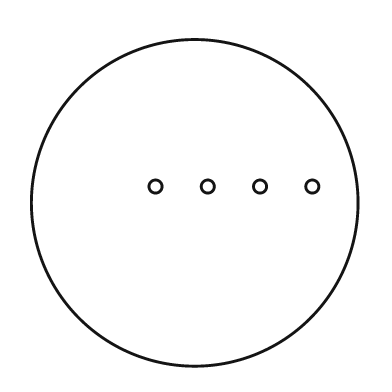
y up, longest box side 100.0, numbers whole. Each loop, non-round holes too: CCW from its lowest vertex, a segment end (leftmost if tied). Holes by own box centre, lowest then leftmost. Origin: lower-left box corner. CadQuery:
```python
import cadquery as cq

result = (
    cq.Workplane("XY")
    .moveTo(50.0, 50.0)
    .circle(50.0)
    .moveTo(38.0, 55.0)
    .circle(2.0)
    .moveTo(54.0, 55.0)
    .circle(2.0)
    .moveTo(70.0, 55.0)
    .circle(2.0)
    .moveTo(86.0, 55.0)
    .circle(2.0)
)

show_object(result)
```